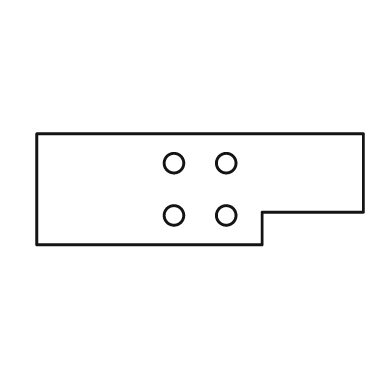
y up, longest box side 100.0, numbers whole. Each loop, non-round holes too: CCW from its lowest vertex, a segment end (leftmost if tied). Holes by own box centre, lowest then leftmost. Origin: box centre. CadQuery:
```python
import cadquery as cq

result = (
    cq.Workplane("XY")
    .moveTo(-50.0, -17.0)
    .lineTo(19.0, -17.0)
    .lineTo(19.0, -7.0)
    .lineTo(50.0, -7.0)
    .lineTo(50.0, 17.0)
    .lineTo(-50.0, 17.0)
    .close()
    .moveTo(-8.0, -8.0)
    .circle(3.0)
    .moveTo(8.0, -8.0)
    .circle(3.0)
    .moveTo(-8.0, 8.0)
    .circle(3.0)
    .moveTo(8.0, 8.0)
    .circle(3.0)
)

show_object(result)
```